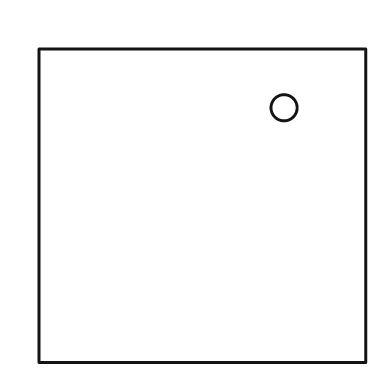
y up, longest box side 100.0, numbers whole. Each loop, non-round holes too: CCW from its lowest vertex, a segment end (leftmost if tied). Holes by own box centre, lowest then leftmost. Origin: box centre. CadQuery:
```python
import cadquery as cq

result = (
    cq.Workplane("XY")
    .moveTo(-50.0, -48.0)
    .lineTo(50.0, -48.0)
    .lineTo(50.0, 48.0)
    .lineTo(-50.0, 48.0)
    .close()
    .moveTo(25.0, 30.0)
    .circle(4.0)
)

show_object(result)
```